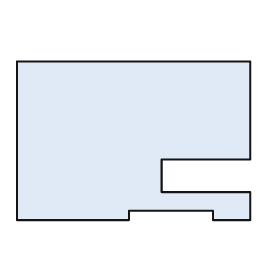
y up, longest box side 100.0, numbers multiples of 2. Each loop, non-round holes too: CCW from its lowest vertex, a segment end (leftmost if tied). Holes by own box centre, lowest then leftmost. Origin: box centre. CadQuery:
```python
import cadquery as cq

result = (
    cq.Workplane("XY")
    .moveTo(-50.0, -34.0)
    .lineTo(-2.0, -34.0)
    .lineTo(-2.0, -30.0)
    .lineTo(34.0, -30.0)
    .lineTo(34.0, -34.0)
    .lineTo(50.0, -34.0)
    .lineTo(50.0, -22.0)
    .lineTo(12.0, -22.0)
    .lineTo(12.0, -8.0)
    .lineTo(50.0, -8.0)
    .lineTo(50.0, 34.0)
    .lineTo(-50.0, 34.0)
    .close()
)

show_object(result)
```